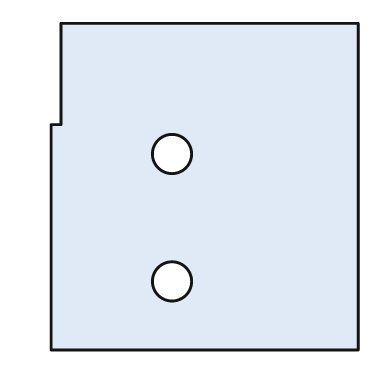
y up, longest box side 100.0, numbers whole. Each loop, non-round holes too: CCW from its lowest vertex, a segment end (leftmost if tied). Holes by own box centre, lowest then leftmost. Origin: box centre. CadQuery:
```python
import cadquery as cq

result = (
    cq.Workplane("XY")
    .moveTo(-47.0, -50.0)
    .lineTo(47.0, -50.0)
    .lineTo(47.0, 50.0)
    .lineTo(-44.0, 50.0)
    .lineTo(-44.0, 19.0)
    .lineTo(-47.0, 19.0)
    .close()
    .moveTo(-10.0, -29.0)
    .circle(6.0)
    .moveTo(-10.0, 10.0)
    .circle(6.0)
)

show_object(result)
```